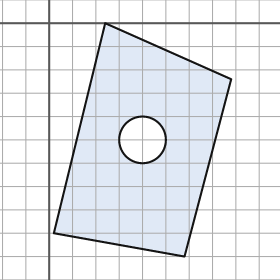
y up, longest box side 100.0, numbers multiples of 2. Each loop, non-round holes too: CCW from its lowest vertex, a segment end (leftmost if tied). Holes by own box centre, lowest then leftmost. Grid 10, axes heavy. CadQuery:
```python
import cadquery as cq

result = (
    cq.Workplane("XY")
    .moveTo(58.0, -100.0)
    .lineTo(78.0, -24.0)
    .lineTo(24.0, 0.0)
    .lineTo(2.0, -90.0)
    .close()
    .moveTo(40.0, -50.0)
    .circle(10.0)
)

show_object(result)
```